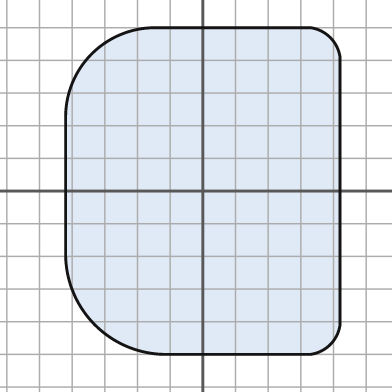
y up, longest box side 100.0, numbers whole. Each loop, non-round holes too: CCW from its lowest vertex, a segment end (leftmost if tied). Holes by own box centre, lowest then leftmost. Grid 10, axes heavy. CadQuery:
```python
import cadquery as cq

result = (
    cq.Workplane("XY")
    .moveTo(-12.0, -50.0)
    .lineTo(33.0, -50.0)
    .threePointArc((39.0, -47.0), (42.0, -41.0))
    .lineTo(42.0, 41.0)
    .threePointArc((39.0, 47.0), (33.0, 50.0))
    .lineTo(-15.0, 50.0)
    .threePointArc((-34.0, 42.0), (-42.0, 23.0))
    .lineTo(-42.0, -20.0)
    .threePointArc((-33.0, -41.0), (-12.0, -50.0))
    .close()
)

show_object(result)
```